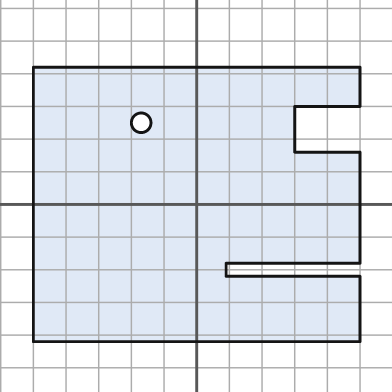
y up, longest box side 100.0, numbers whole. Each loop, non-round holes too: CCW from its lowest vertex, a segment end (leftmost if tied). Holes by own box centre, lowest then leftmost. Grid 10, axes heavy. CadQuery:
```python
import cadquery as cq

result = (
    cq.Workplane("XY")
    .moveTo(-50.0, -42.0)
    .lineTo(50.0, -42.0)
    .lineTo(50.0, -22.0)
    .lineTo(9.0, -22.0)
    .lineTo(9.0, -18.0)
    .lineTo(50.0, -18.0)
    .lineTo(50.0, 16.0)
    .lineTo(30.0, 16.0)
    .lineTo(30.0, 30.0)
    .lineTo(50.0, 30.0)
    .lineTo(50.0, 42.0)
    .lineTo(-50.0, 42.0)
    .close()
    .moveTo(-17.0, 25.0)
    .circle(3.0)
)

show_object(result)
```